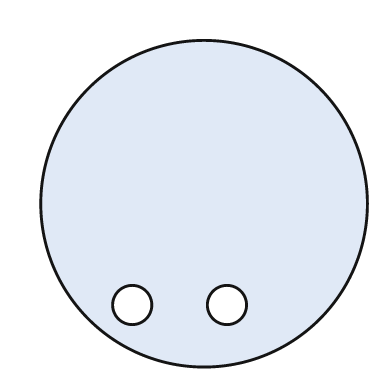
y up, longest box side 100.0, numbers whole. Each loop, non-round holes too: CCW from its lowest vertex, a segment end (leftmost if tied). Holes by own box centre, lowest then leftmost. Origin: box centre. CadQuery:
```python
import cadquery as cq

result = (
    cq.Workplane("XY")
    .moveTo(0.0, 0.0)
    .circle(50.0)
    .moveTo(-22.0, -31.0)
    .circle(6.0)
    .moveTo(7.0, -31.0)
    .circle(6.0)
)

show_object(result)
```